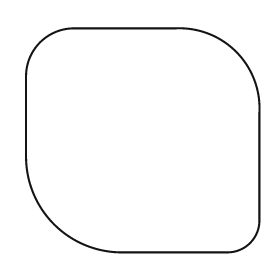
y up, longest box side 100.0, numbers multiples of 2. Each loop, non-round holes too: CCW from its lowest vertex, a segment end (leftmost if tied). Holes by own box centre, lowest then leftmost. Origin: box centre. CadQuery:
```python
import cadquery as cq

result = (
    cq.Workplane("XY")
    .moveTo(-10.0, -48.0)
    .lineTo(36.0, -48.0)
    .threePointArc((46.0, -44.0), (50.0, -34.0))
    .lineTo(50.0, 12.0)
    .threePointArc((40.0, 38.0), (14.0, 48.0))
    .lineTo(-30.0, 48.0)
    .threePointArc((-44.0, 42.0), (-50.0, 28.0))
    .lineTo(-50.0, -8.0)
    .threePointArc((-38.0, -36.0), (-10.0, -48.0))
    .close()
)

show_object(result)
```